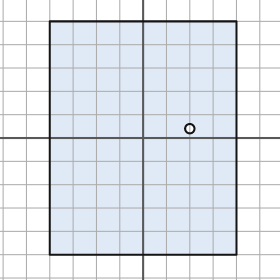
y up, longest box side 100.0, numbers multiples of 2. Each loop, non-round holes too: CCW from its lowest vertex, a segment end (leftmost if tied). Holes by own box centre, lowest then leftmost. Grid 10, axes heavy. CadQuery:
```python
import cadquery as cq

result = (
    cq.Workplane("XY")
    .moveTo(-40.0, -50.0)
    .lineTo(40.0, -50.0)
    .lineTo(40.0, 50.0)
    .lineTo(-40.0, 50.0)
    .close()
    .moveTo(20.0, 4.0)
    .circle(2.0)
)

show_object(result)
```